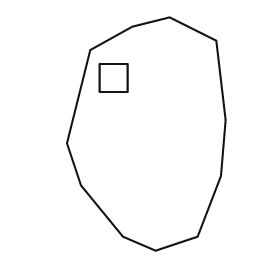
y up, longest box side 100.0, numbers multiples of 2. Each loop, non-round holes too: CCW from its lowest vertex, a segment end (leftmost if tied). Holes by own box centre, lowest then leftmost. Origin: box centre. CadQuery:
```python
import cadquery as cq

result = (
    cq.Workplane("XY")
    .moveTo(4.0, -50.0)
    .lineTo(22.0, -44.0)
    .lineTo(32.0, -18.0)
    .lineTo(34.0, 6.0)
    .lineTo(30.0, 40.0)
    .lineTo(10.0, 50.0)
    .lineTo(-6.0, 46.0)
    .lineTo(-24.0, 36.0)
    .lineTo(-34.0, -4.0)
    .lineTo(-28.0, -22.0)
    .lineTo(-10.0, -44.0)
    .close()
    .moveTo(-20.0, 18.0)
    .lineTo(-8.0, 18.0)
    .lineTo(-8.0, 30.0)
    .lineTo(-20.0, 30.0)
    .close()
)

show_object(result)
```